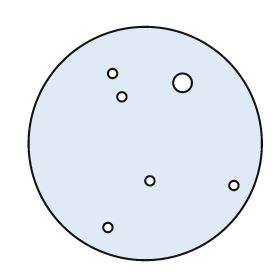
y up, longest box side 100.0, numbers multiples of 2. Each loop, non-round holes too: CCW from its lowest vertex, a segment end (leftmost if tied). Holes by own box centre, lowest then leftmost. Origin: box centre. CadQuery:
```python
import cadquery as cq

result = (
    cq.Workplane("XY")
    .moveTo(0.0, 0.0)
    .circle(50.0)
    .moveTo(-16.0, -36.0)
    .circle(2.0)
    .moveTo(38.0, -18.0)
    .circle(2.0)
    .moveTo(2.0, -16.0)
    .circle(2.0)
    .moveTo(-10.0, 20.0)
    .circle(2.0)
    .moveTo(16.0, 26.0)
    .circle(4.0)
    .moveTo(-14.0, 30.0)
    .circle(2.0)
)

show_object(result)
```